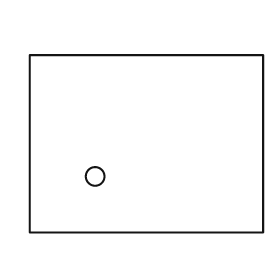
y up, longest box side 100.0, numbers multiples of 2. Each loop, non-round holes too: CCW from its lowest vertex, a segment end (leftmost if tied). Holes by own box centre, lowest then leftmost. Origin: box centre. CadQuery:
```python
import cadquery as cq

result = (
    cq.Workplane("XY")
    .moveTo(-50.0, -38.0)
    .lineTo(50.0, -38.0)
    .lineTo(50.0, 38.0)
    .lineTo(-50.0, 38.0)
    .close()
    .moveTo(-22.0, -14.0)
    .circle(4.0)
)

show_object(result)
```